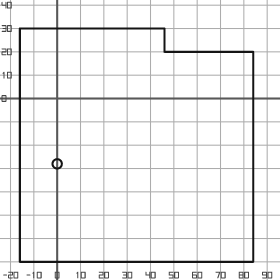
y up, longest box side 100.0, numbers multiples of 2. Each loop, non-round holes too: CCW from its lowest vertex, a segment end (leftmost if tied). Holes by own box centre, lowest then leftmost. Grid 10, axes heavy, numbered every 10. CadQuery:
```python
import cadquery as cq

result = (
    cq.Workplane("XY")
    .moveTo(-16.0, -70.0)
    .lineTo(84.0, -70.0)
    .lineTo(84.0, 20.0)
    .lineTo(46.0, 20.0)
    .lineTo(46.0, 30.0)
    .lineTo(-16.0, 30.0)
    .close()
    .moveTo(0.0, -28.0)
    .circle(2.0)
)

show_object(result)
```